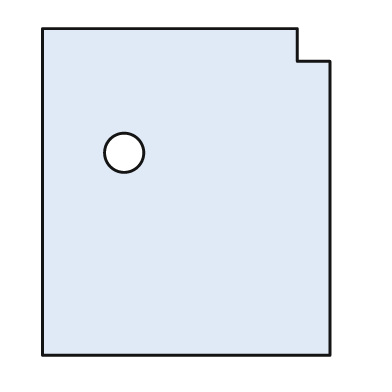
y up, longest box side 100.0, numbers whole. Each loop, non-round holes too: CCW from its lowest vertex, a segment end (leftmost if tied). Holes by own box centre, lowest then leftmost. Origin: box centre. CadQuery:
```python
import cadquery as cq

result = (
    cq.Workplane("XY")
    .moveTo(-44.0, -50.0)
    .lineTo(44.0, -50.0)
    .lineTo(44.0, 40.0)
    .lineTo(34.0, 40.0)
    .lineTo(34.0, 50.0)
    .lineTo(-44.0, 50.0)
    .close()
    .moveTo(-19.0, 12.0)
    .circle(6.0)
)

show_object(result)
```